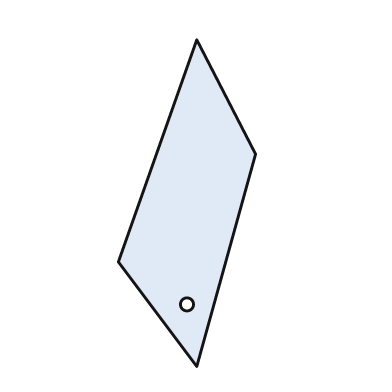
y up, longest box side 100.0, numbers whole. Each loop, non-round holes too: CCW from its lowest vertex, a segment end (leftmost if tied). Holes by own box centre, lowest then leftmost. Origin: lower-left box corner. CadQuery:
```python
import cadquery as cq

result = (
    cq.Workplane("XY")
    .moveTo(24.0, 0.0)
    .lineTo(42.0, 65.0)
    .lineTo(24.0, 100.0)
    .lineTo(0.0, 32.0)
    .close()
    .moveTo(21.0, 19.0)
    .circle(2.0)
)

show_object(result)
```